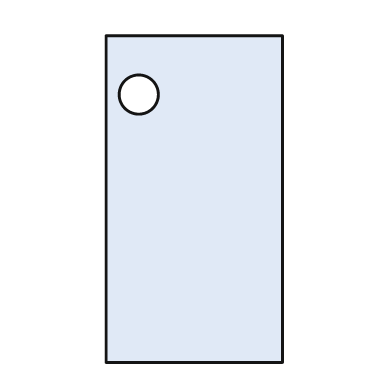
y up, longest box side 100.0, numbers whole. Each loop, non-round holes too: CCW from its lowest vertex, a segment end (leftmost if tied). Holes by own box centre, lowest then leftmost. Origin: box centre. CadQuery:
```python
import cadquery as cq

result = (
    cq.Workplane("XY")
    .moveTo(-27.0, -50.0)
    .lineTo(27.0, -50.0)
    .lineTo(27.0, 50.0)
    .lineTo(-27.0, 50.0)
    .close()
    .moveTo(-17.0, 32.0)
    .circle(6.0)
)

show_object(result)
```